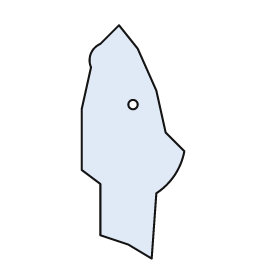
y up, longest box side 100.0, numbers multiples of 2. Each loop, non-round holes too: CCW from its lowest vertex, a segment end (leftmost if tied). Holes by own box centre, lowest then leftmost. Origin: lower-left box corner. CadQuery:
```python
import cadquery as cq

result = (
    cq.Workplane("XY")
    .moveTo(30.0, 0.0)
    .lineTo(32.0, 28.0)
    .threePointArc((40.0, 36.0), (44.0, 46.0))
    .lineTo(36.0, 54.0)
    .lineTo(32.0, 72.0)
    .lineTo(24.0, 90.0)
    .lineTo(16.0, 100.0)
    .lineTo(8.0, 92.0)
    .threePointArc((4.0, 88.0), (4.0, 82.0))
    .lineTo(0.0, 64.0)
    .lineTo(0.0, 38.0)
    .lineTo(8.0, 32.0)
    .lineTo(8.0, 10.0)
    .lineTo(20.0, 6.0)
    .close()
    .moveTo(22.0, 66.0)
    .circle(2.0)
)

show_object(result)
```